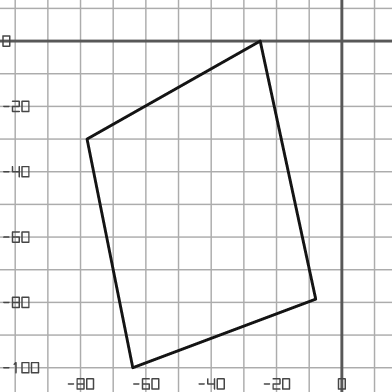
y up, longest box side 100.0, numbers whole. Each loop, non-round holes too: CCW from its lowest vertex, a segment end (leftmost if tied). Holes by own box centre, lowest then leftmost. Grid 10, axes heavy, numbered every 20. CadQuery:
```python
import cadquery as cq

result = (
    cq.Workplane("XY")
    .moveTo(-64.0, -100.0)
    .lineTo(-8.0, -79.0)
    .lineTo(-25.0, 0.0)
    .lineTo(-78.0, -30.0)
    .close()
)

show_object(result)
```